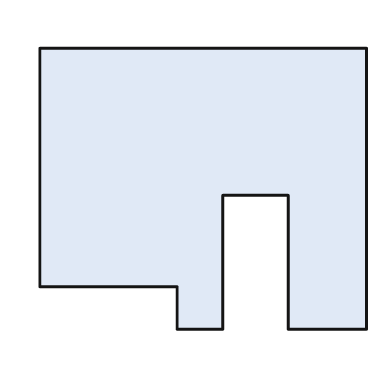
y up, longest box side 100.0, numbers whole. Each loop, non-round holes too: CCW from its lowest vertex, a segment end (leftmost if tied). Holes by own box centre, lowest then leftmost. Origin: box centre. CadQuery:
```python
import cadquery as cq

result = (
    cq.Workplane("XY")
    .moveTo(-8.0, -43.0)
    .lineTo(6.0, -43.0)
    .lineTo(6.0, -2.0)
    .lineTo(26.0, -2.0)
    .lineTo(26.0, -43.0)
    .lineTo(50.0, -43.0)
    .lineTo(50.0, 43.0)
    .lineTo(-50.0, 43.0)
    .lineTo(-50.0, -30.0)
    .lineTo(-8.0, -30.0)
    .close()
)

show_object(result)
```